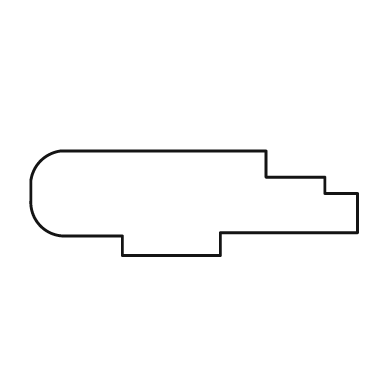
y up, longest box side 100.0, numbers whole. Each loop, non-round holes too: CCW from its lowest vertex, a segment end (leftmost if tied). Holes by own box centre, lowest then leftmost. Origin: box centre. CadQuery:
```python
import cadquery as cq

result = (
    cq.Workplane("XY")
    .moveTo(-22.0, -16.0)
    .lineTo(8.0, -16.0)
    .lineTo(8.0, -9.0)
    .lineTo(50.0, -9.0)
    .lineTo(50.0, 3.0)
    .lineTo(40.0, 3.0)
    .lineTo(40.0, 8.0)
    .lineTo(22.0, 8.0)
    .lineTo(22.0, 16.0)
    .lineTo(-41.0, 16.0)
    .threePointArc((-47.0, 13.0), (-50.0, 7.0))
    .lineTo(-50.0, 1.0)
    .threePointArc((-47.0, -7.0), (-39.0, -10.0))
    .lineTo(-22.0, -10.0)
    .close()
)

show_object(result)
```